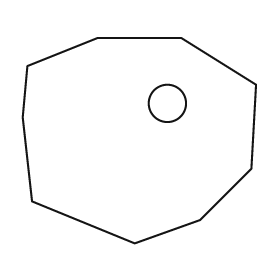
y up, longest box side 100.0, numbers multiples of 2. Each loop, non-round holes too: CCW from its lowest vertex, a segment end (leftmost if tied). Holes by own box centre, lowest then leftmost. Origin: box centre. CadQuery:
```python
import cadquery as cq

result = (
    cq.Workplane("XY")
    .moveTo(-2.0, -44.0)
    .lineTo(26.0, -34.0)
    .lineTo(48.0, -12.0)
    .lineTo(50.0, 24.0)
    .lineTo(18.0, 44.0)
    .lineTo(-18.0, 44.0)
    .lineTo(-48.0, 32.0)
    .lineTo(-50.0, 10.0)
    .lineTo(-46.0, -26.0)
    .close()
    .moveTo(12.0, 16.0)
    .circle(8.0)
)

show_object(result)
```